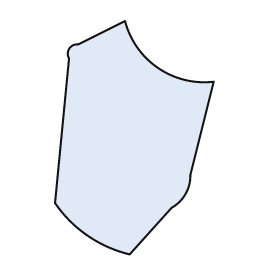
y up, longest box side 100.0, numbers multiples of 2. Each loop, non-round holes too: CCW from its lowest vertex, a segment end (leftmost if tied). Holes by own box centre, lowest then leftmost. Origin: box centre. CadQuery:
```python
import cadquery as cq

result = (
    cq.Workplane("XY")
    .moveTo(-2.0, -50.0)
    .lineTo(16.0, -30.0)
    .threePointArc((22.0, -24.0), (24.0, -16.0))
    .lineTo(34.0, 24.0)
    .threePointArc((10.0, 30.0), (-4.0, 50.0))
    .lineTo(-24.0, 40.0)
    .threePointArc((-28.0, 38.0), (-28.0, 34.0))
    .lineTo(-34.0, -28.0)
    .threePointArc((-20.0, -42.0), (-2.0, -50.0))
    .close()
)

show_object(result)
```